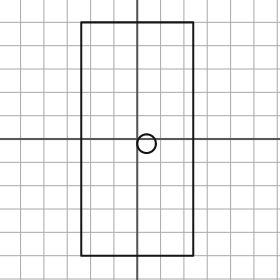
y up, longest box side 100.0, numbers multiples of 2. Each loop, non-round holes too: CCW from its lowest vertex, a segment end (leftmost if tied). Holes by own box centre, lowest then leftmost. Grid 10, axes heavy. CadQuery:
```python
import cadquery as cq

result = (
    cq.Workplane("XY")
    .moveTo(-24.0, -50.0)
    .lineTo(24.0, -50.0)
    .lineTo(24.0, 50.0)
    .lineTo(-24.0, 50.0)
    .close()
    .moveTo(4.0, -2.0)
    .circle(4.0)
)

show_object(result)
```